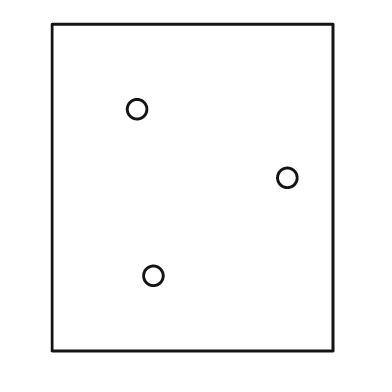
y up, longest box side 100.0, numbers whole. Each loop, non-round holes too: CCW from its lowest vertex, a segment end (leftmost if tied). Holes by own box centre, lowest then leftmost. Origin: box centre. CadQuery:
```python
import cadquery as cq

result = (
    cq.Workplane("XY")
    .moveTo(-43.0, -50.0)
    .lineTo(43.0, -50.0)
    .lineTo(43.0, 50.0)
    .lineTo(-43.0, 50.0)
    .close()
    .moveTo(-12.0, -27.0)
    .circle(3.0)
    .moveTo(29.0, 3.0)
    .circle(3.0)
    .moveTo(-17.0, 24.0)
    .circle(3.0)
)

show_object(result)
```